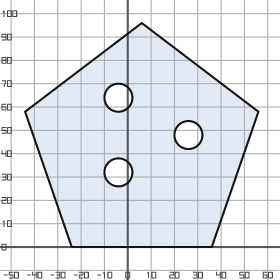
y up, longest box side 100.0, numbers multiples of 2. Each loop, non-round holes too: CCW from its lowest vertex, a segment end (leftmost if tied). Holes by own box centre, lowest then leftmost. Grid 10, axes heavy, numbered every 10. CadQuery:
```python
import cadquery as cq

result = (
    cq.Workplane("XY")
    .moveTo(-24.0, 0.0)
    .lineTo(36.0, 0.0)
    .lineTo(56.0, 58.0)
    .lineTo(6.0, 96.0)
    .lineTo(-44.0, 58.0)
    .close()
    .moveTo(-4.0, 32.0)
    .circle(6.0)
    .moveTo(26.0, 48.0)
    .circle(6.0)
    .moveTo(-4.0, 64.0)
    .circle(6.0)
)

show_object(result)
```